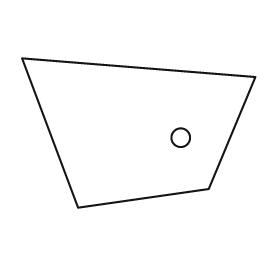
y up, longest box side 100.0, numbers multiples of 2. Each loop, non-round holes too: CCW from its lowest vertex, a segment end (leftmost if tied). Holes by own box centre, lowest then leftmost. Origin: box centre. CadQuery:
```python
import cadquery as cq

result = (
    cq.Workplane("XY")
    .moveTo(-26.0, -32.0)
    .lineTo(30.0, -24.0)
    .lineTo(50.0, 24.0)
    .lineTo(-50.0, 32.0)
    .close()
    .moveTo(18.0, -2.0)
    .circle(4.0)
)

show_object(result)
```